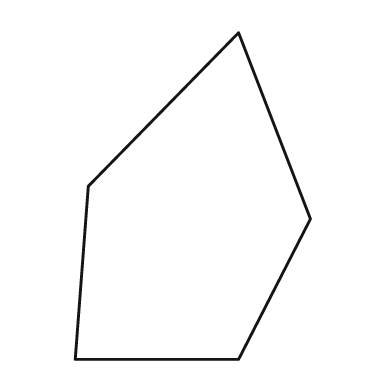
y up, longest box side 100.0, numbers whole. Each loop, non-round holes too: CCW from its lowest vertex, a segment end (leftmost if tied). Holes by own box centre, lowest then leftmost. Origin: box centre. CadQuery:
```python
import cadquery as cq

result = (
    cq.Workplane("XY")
    .moveTo(-36.0, -50.0)
    .lineTo(14.0, -50.0)
    .lineTo(36.0, -7.0)
    .lineTo(14.0, 50.0)
    .lineTo(-32.0, 3.0)
    .close()
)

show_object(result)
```